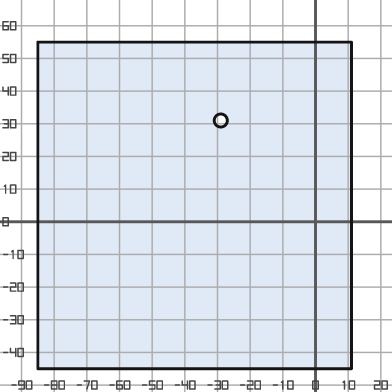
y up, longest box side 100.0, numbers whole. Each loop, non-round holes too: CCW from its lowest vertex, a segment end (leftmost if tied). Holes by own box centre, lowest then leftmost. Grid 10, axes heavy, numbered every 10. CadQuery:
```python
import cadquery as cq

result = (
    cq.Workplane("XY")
    .moveTo(-85.0, -45.0)
    .lineTo(11.0, -45.0)
    .lineTo(11.0, 55.0)
    .lineTo(-85.0, 55.0)
    .close()
    .moveTo(-29.0, 31.0)
    .circle(2.0)
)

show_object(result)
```